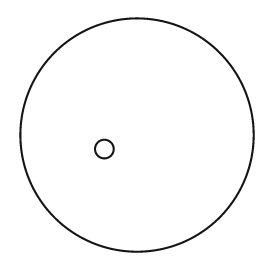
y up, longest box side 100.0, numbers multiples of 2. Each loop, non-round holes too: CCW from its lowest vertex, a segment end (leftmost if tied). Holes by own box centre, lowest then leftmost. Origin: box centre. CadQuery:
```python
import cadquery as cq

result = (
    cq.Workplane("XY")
    .moveTo(0.0, 0.0)
    .circle(50.0)
    .moveTo(-14.0, -6.0)
    .circle(4.0)
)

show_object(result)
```